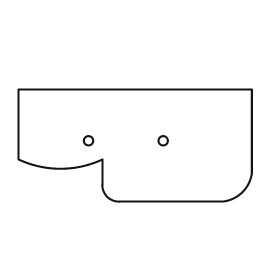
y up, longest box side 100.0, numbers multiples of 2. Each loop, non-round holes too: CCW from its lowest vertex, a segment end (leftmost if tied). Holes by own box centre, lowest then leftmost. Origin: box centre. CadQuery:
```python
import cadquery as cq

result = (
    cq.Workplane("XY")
    .moveTo(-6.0, -24.0)
    .lineTo(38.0, -24.0)
    .threePointArc((46.0, -20.0), (50.0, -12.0))
    .lineTo(50.0, 24.0)
    .lineTo(-50.0, 24.0)
    .lineTo(-50.0, -6.0)
    .threePointArc((-32.0, -10.0), (-14.0, -6.0))
    .lineTo(-14.0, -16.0)
    .threePointArc((-12.0, -22.0), (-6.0, -24.0))
    .close()
    .moveTo(-20.0, 2.0)
    .circle(2.0)
    .moveTo(12.0, 2.0)
    .circle(2.0)
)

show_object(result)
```